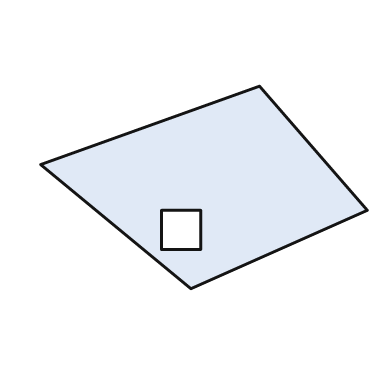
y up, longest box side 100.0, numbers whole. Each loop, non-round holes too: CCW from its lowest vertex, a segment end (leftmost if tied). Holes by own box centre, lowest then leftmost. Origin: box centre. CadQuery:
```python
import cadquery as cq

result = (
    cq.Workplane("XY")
    .moveTo(-4.0, -31.0)
    .lineTo(50.0, -7.0)
    .lineTo(17.0, 31.0)
    .lineTo(-50.0, 7.0)
    .close()
    .moveTo(-13.0, -19.0)
    .lineTo(-1.0, -19.0)
    .lineTo(-1.0, -7.0)
    .lineTo(-13.0, -7.0)
    .close()
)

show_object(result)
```